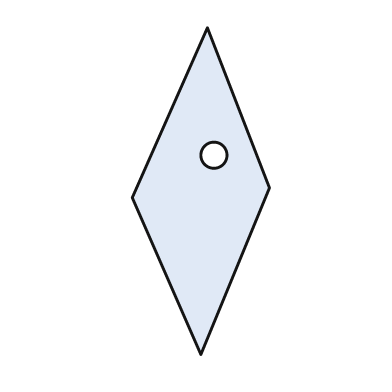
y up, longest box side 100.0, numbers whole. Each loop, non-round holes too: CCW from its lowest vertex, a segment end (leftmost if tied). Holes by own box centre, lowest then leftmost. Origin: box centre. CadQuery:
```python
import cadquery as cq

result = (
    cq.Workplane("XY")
    .moveTo(0.0, -50.0)
    .lineTo(21.0, 1.0)
    .lineTo(2.0, 50.0)
    .lineTo(-21.0, -2.0)
    .close()
    .moveTo(4.0, 11.0)
    .circle(4.0)
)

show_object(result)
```